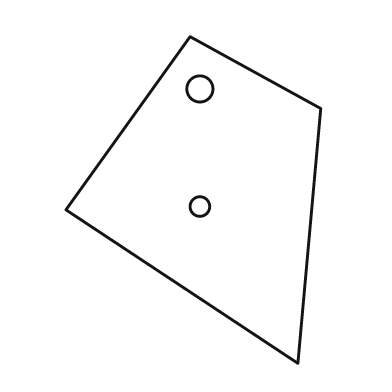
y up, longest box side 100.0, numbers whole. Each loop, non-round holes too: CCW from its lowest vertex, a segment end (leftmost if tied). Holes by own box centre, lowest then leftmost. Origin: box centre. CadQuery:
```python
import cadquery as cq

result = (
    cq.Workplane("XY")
    .moveTo(32.0, -50.0)
    .lineTo(39.0, 28.0)
    .lineTo(-1.0, 50.0)
    .lineTo(-39.0, -3.0)
    .close()
    .moveTo(2.0, -2.0)
    .circle(3.0)
    .moveTo(2.0, 34.0)
    .circle(4.0)
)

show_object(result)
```